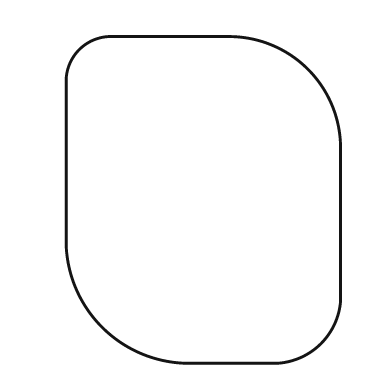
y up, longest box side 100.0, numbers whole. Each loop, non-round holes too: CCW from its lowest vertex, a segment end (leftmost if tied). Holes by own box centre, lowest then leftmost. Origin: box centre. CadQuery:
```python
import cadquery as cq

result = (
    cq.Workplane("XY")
    .moveTo(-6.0, -50.0)
    .lineTo(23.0, -50.0)
    .threePointArc((36.0, -44.0), (42.0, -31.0))
    .lineTo(42.0, 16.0)
    .threePointArc((32.0, 40.0), (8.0, 50.0))
    .lineTo(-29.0, 50.0)
    .threePointArc((-38.0, 46.0), (-42.0, 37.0))
    .lineTo(-42.0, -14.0)
    .threePointArc((-31.0, -39.0), (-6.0, -50.0))
    .close()
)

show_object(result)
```